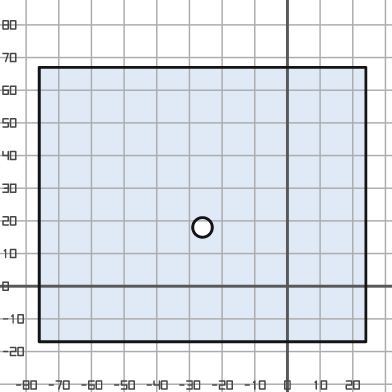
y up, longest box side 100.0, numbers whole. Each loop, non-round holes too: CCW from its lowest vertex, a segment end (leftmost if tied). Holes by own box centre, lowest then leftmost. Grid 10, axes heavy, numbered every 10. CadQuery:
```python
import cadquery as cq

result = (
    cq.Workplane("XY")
    .moveTo(-76.0, -17.0)
    .lineTo(24.0, -17.0)
    .lineTo(24.0, 67.0)
    .lineTo(-76.0, 67.0)
    .close()
    .moveTo(-26.0, 18.0)
    .circle(3.0)
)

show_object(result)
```